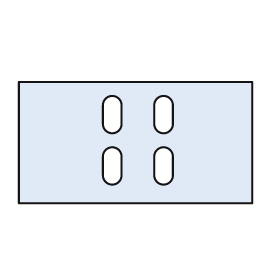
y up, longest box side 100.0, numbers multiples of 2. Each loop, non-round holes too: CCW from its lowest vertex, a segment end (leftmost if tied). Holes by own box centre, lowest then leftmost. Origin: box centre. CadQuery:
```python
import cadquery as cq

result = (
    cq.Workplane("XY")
    .moveTo(-50.0, -26.0)
    .lineTo(50.0, -26.0)
    .lineTo(50.0, 26.0)
    .lineTo(-50.0, 26.0)
    .close()
    .moveTo(-14.0, -14.0)
    .threePointArc((-10.0, -18.0), (-6.0, -14.0))
    .lineTo(-6.0, -6.0)
    .threePointArc((-10.0, -2.0), (-14.0, -6.0))
    .close()
    .moveTo(8.0, -14.0)
    .threePointArc((12.0, -18.0), (16.0, -14.0))
    .lineTo(16.0, -6.0)
    .threePointArc((12.0, -2.0), (8.0, -6.0))
    .close()
    .moveTo(-14.0, 8.0)
    .threePointArc((-10.0, 4.0), (-6.0, 8.0))
    .lineTo(-6.0, 16.0)
    .threePointArc((-10.0, 20.0), (-14.0, 16.0))
    .close()
    .moveTo(8.0, 8.0)
    .threePointArc((12.0, 4.0), (16.0, 8.0))
    .lineTo(16.0, 16.0)
    .threePointArc((12.0, 20.0), (8.0, 16.0))
    .close()
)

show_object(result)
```